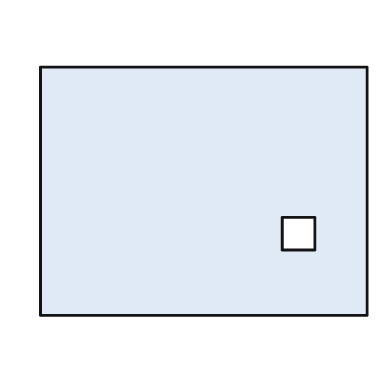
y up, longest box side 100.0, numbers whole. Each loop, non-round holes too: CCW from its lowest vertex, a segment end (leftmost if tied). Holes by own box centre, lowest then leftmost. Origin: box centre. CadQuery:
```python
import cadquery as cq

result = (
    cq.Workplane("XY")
    .moveTo(-50.0, -38.0)
    .lineTo(50.0, -38.0)
    .lineTo(50.0, 38.0)
    .lineTo(-50.0, 38.0)
    .close()
    .moveTo(24.0, -18.0)
    .lineTo(34.0, -18.0)
    .lineTo(34.0, -8.0)
    .lineTo(24.0, -8.0)
    .close()
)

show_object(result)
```